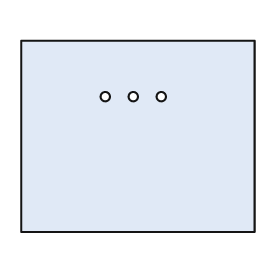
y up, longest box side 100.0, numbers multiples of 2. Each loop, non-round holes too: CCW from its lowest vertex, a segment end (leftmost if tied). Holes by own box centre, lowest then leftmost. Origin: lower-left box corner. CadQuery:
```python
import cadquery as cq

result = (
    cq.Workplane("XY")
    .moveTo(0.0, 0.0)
    .lineTo(100.0, 0.0)
    .lineTo(100.0, 82.0)
    .lineTo(0.0, 82.0)
    .close()
    .moveTo(36.0, 58.0)
    .circle(2.0)
    .moveTo(48.0, 58.0)
    .circle(2.0)
    .moveTo(60.0, 58.0)
    .circle(2.0)
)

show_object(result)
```